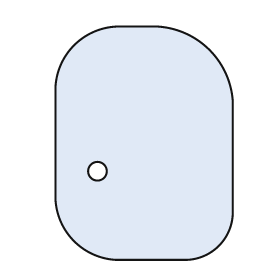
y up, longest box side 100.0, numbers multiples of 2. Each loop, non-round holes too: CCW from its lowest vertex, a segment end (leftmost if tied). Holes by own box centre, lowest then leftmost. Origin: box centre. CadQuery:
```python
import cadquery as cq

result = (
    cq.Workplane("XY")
    .moveTo(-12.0, -50.0)
    .lineTo(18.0, -50.0)
    .threePointArc((32.0, -44.0), (38.0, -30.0))
    .lineTo(38.0, 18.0)
    .threePointArc((28.0, 40.0), (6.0, 50.0))
    .lineTo(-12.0, 50.0)
    .threePointArc((-30.0, 42.0), (-38.0, 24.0))
    .lineTo(-38.0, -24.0)
    .threePointArc((-30.0, -42.0), (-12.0, -50.0))
    .close()
    .moveTo(-20.0, -12.0)
    .circle(4.0)
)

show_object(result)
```